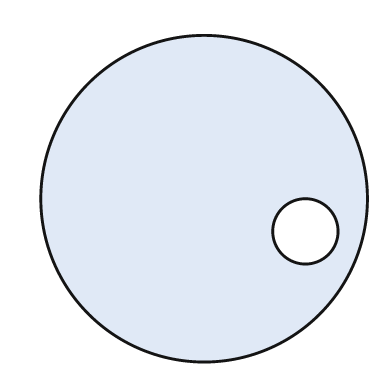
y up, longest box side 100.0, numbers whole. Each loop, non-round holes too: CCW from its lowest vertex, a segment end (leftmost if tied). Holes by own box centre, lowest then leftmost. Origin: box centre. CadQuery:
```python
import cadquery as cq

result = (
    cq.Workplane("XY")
    .moveTo(0.0, 0.0)
    .circle(50.0)
    .moveTo(31.0, -10.0)
    .circle(10.0)
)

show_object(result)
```